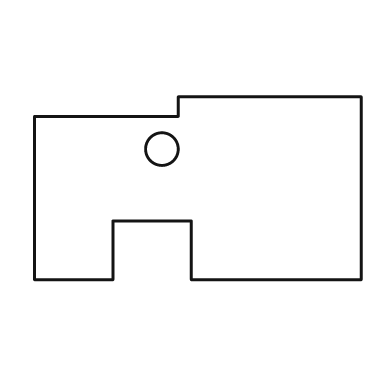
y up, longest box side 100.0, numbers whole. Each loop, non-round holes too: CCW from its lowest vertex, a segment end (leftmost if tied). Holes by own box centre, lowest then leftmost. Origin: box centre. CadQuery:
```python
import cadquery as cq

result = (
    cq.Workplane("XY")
    .moveTo(-50.0, -28.0)
    .lineTo(-26.0, -28.0)
    .lineTo(-26.0, -10.0)
    .lineTo(-2.0, -10.0)
    .lineTo(-2.0, -28.0)
    .lineTo(50.0, -28.0)
    .lineTo(50.0, 28.0)
    .lineTo(-6.0, 28.0)
    .lineTo(-6.0, 22.0)
    .lineTo(-50.0, 22.0)
    .close()
    .moveTo(-11.0, 12.0)
    .circle(5.0)
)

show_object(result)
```